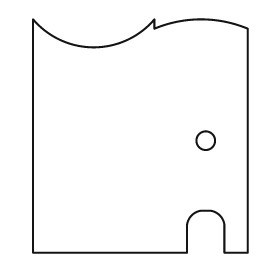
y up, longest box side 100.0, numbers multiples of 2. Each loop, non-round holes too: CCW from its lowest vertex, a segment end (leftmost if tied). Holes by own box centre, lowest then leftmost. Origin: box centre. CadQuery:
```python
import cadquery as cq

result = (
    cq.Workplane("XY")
    .moveTo(-46.0, -50.0)
    .lineTo(20.0, -50.0)
    .lineTo(20.0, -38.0)
    .threePointArc((22.0, -34.0), (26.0, -32.0))
    .lineTo(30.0, -32.0)
    .threePointArc((34.0, -34.0), (36.0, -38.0))
    .lineTo(36.0, -50.0)
    .lineTo(46.0, -50.0)
    .lineTo(46.0, 46.0)
    .threePointArc((26.0, 50.0), (6.0, 46.0))
    .lineTo(6.0, 50.0)
    .threePointArc((-20.0, 38.0), (-46.0, 50.0))
    .close()
    .moveTo(28.0, -2.0)
    .circle(4.0)
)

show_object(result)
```